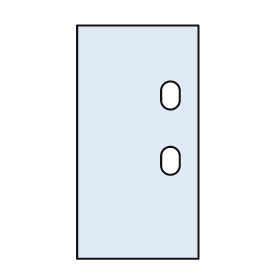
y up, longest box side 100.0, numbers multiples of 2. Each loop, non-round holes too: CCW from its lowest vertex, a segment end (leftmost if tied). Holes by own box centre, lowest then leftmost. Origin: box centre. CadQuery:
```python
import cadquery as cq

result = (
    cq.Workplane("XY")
    .moveTo(-26.0, -50.0)
    .lineTo(26.0, -50.0)
    .lineTo(26.0, 50.0)
    .lineTo(-26.0, 50.0)
    .close()
    .moveTo(10.0, -10.0)
    .threePointArc((14.0, -14.0), (18.0, -10.0))
    .lineTo(18.0, -6.0)
    .threePointArc((14.0, -2.0), (10.0, -6.0))
    .close()
    .moveTo(10.0, 18.0)
    .threePointArc((14.0, 14.0), (18.0, 18.0))
    .lineTo(18.0, 22.0)
    .threePointArc((14.0, 26.0), (10.0, 22.0))
    .close()
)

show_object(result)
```